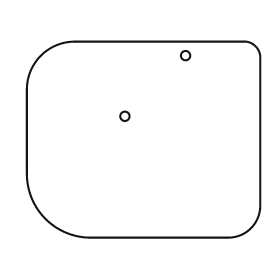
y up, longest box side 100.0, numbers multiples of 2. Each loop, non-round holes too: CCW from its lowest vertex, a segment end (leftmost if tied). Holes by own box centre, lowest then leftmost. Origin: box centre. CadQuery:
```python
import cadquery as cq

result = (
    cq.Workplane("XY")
    .moveTo(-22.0, -42.0)
    .lineTo(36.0, -42.0)
    .threePointArc((46.0, -38.0), (50.0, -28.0))
    .lineTo(50.0, 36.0)
    .threePointArc((48.0, 40.0), (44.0, 42.0))
    .lineTo(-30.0, 42.0)
    .threePointArc((-44.0, 36.0), (-50.0, 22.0))
    .lineTo(-50.0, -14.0)
    .threePointArc((-42.0, -34.0), (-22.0, -42.0))
    .close()
    .moveTo(-8.0, 10.0)
    .circle(2.0)
    .moveTo(18.0, 36.0)
    .circle(2.0)
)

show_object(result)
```